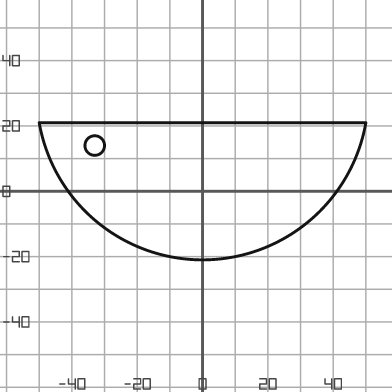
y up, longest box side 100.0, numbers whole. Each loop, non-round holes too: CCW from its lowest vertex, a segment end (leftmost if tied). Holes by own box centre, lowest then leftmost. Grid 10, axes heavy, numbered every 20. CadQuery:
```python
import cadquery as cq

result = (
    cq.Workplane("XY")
    .moveTo(-50.0, 21.0)
    .threePointArc((0.0, -21.0), (50.0, 21.0))
    .close()
    .moveTo(-33.0, 14.0)
    .circle(3.0)
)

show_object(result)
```